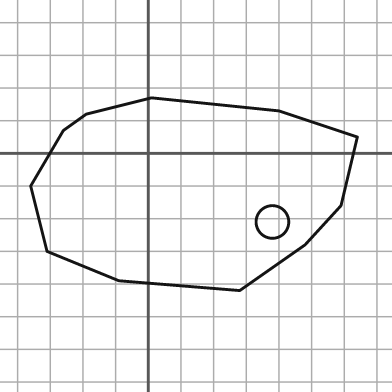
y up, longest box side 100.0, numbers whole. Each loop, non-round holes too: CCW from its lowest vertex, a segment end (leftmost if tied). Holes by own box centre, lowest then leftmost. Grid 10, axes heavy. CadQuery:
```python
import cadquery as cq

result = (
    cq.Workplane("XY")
    .moveTo(28.0, -42.0)
    .lineTo(48.0, -28.0)
    .lineTo(59.0, -16.0)
    .lineTo(64.0, 5.0)
    .lineTo(40.0, 13.0)
    .lineTo(1.0, 17.0)
    .lineTo(-19.0, 12.0)
    .lineTo(-26.0, 7.0)
    .lineTo(-36.0, -10.0)
    .lineTo(-31.0, -30.0)
    .lineTo(-9.0, -39.0)
    .close()
    .moveTo(38.0, -21.0)
    .circle(5.0)
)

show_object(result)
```